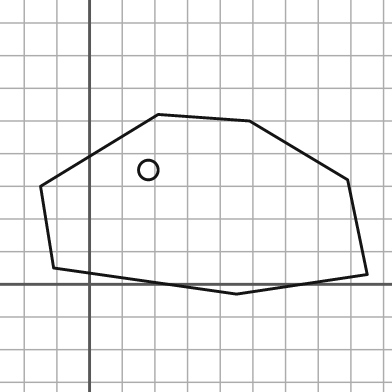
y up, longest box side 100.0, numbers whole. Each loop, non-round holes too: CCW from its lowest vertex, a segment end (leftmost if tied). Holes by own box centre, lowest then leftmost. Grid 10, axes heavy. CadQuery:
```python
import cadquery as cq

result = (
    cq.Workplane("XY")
    .moveTo(45.0, -3.0)
    .lineTo(85.0, 3.0)
    .lineTo(79.0, 32.0)
    .lineTo(49.0, 50.0)
    .lineTo(21.0, 52.0)
    .lineTo(-15.0, 30.0)
    .lineTo(-11.0, 5.0)
    .close()
    .moveTo(18.0, 35.0)
    .circle(3.0)
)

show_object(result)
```